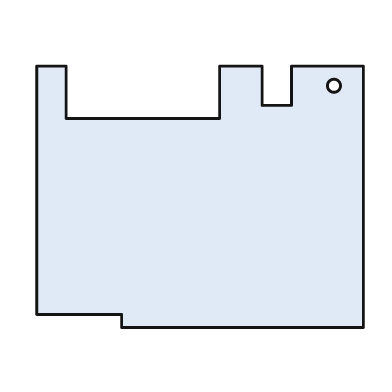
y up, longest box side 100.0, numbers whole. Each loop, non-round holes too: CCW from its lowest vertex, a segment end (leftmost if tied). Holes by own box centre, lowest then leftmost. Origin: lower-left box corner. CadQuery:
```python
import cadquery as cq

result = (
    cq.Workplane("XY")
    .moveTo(26.0, 0.0)
    .lineTo(100.0, 0.0)
    .lineTo(100.0, 80.0)
    .lineTo(78.0, 80.0)
    .lineTo(78.0, 68.0)
    .lineTo(69.0, 68.0)
    .lineTo(69.0, 80.0)
    .lineTo(56.0, 80.0)
    .lineTo(56.0, 64.0)
    .lineTo(9.0, 64.0)
    .lineTo(9.0, 80.0)
    .lineTo(0.0, 80.0)
    .lineTo(0.0, 4.0)
    .lineTo(26.0, 4.0)
    .close()
    .moveTo(91.0, 74.0)
    .circle(2.0)
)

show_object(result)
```